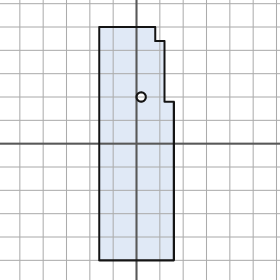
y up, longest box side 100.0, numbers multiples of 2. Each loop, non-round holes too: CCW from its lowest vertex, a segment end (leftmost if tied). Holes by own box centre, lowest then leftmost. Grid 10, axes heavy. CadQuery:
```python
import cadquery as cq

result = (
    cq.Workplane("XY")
    .moveTo(-16.0, -50.0)
    .lineTo(16.0, -50.0)
    .lineTo(16.0, 18.0)
    .lineTo(12.0, 18.0)
    .lineTo(12.0, 44.0)
    .lineTo(8.0, 44.0)
    .lineTo(8.0, 50.0)
    .lineTo(-16.0, 50.0)
    .close()
    .moveTo(2.0, 20.0)
    .circle(2.0)
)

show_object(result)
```